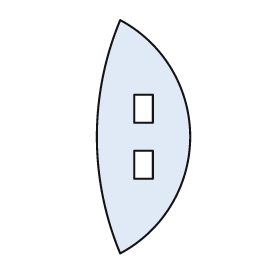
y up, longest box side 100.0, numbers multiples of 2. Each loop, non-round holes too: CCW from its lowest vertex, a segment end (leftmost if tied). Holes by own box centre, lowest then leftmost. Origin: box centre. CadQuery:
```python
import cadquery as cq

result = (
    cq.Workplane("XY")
    .moveTo(-10.0, -50.0)
    .threePointArc((20.0, 0.0), (-10.0, 50.0))
    .threePointArc((-20.0, 0.0), (-10.0, -50.0))
    .close()
    .moveTo(-4.0, -18.0)
    .lineTo(4.0, -18.0)
    .lineTo(4.0, -6.0)
    .lineTo(-4.0, -6.0)
    .close()
    .moveTo(-4.0, 6.0)
    .lineTo(4.0, 6.0)
    .lineTo(4.0, 18.0)
    .lineTo(-4.0, 18.0)
    .close()
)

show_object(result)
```